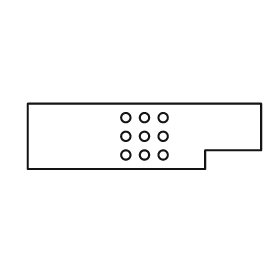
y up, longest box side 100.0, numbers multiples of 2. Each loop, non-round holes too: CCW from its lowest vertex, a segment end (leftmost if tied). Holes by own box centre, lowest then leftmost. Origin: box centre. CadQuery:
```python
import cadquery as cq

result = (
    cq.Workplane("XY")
    .moveTo(-50.0, -14.0)
    .lineTo(26.0, -14.0)
    .lineTo(26.0, -6.0)
    .lineTo(50.0, -6.0)
    .lineTo(50.0, 14.0)
    .lineTo(-50.0, 14.0)
    .close()
    .moveTo(-8.0, -8.0)
    .circle(2.0)
    .moveTo(0.0, -8.0)
    .circle(2.0)
    .moveTo(8.0, -8.0)
    .circle(2.0)
    .moveTo(-8.0, 0.0)
    .circle(2.0)
    .moveTo(0.0, 0.0)
    .circle(2.0)
    .moveTo(8.0, 0.0)
    .circle(2.0)
    .moveTo(-8.0, 8.0)
    .circle(2.0)
    .moveTo(0.0, 8.0)
    .circle(2.0)
    .moveTo(8.0, 8.0)
    .circle(2.0)
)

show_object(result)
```